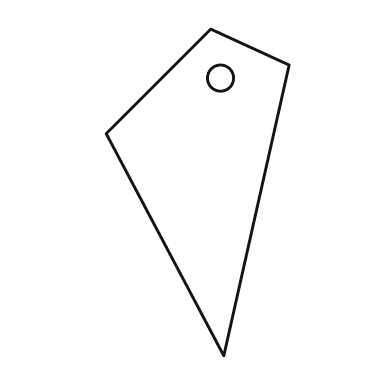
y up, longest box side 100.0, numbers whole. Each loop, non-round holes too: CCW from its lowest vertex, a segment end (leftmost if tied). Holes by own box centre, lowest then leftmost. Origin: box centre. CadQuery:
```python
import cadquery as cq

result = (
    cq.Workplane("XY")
    .moveTo(8.0, -50.0)
    .lineTo(28.0, 39.0)
    .lineTo(4.0, 50.0)
    .lineTo(-28.0, 18.0)
    .close()
    .moveTo(7.0, 35.0)
    .circle(4.0)
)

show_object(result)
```